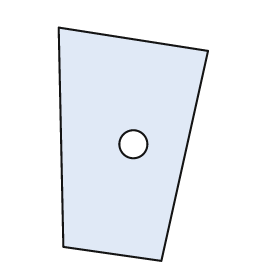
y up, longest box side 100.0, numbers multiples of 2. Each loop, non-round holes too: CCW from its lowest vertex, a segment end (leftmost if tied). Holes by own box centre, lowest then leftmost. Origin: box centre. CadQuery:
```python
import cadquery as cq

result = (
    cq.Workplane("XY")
    .moveTo(12.0, -50.0)
    .lineTo(32.0, 40.0)
    .lineTo(-32.0, 50.0)
    .lineTo(-30.0, -44.0)
    .close()
    .moveTo(0.0, 0.0)
    .circle(6.0)
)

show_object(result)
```